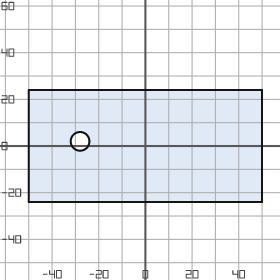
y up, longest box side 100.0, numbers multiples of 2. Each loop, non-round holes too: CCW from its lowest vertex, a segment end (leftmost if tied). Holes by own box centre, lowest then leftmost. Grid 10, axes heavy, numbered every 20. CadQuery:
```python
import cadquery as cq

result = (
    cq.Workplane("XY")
    .moveTo(-50.0, -24.0)
    .lineTo(50.0, -24.0)
    .lineTo(50.0, 24.0)
    .lineTo(-50.0, 24.0)
    .close()
    .moveTo(-28.0, 2.0)
    .circle(4.0)
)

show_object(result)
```